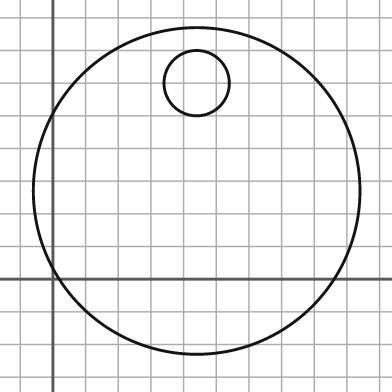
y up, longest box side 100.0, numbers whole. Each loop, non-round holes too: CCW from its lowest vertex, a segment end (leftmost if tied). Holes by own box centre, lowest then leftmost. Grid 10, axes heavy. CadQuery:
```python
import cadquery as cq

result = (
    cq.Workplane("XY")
    .moveTo(44.0, 27.0)
    .circle(50.0)
    .moveTo(44.0, 60.0)
    .circle(10.0)
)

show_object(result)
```